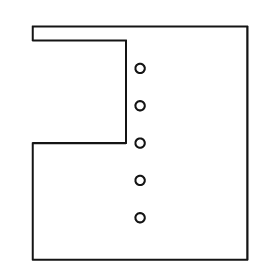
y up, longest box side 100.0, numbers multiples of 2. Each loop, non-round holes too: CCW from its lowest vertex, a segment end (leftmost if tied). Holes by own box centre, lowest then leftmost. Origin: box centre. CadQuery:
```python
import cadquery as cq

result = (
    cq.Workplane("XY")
    .moveTo(-46.0, -50.0)
    .lineTo(46.0, -50.0)
    .lineTo(46.0, 50.0)
    .lineTo(-46.0, 50.0)
    .lineTo(-46.0, 44.0)
    .lineTo(-6.0, 44.0)
    .lineTo(-6.0, 0.0)
    .lineTo(-46.0, 0.0)
    .close()
    .moveTo(0.0, -32.0)
    .circle(2.0)
    .moveTo(0.0, -16.0)
    .circle(2.0)
    .moveTo(0.0, 0.0)
    .circle(2.0)
    .moveTo(0.0, 16.0)
    .circle(2.0)
    .moveTo(0.0, 32.0)
    .circle(2.0)
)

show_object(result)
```